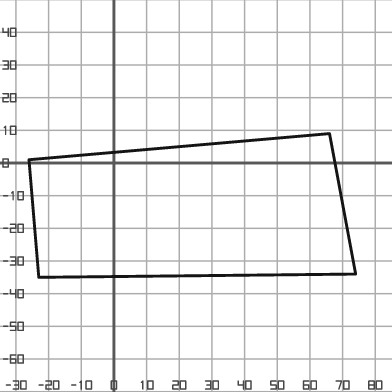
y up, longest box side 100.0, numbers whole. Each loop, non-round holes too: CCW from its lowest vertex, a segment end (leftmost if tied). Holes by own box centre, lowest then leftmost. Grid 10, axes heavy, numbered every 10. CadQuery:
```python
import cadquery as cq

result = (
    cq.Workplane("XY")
    .moveTo(-23.0, -35.0)
    .lineTo(74.0, -34.0)
    .lineTo(66.0, 9.0)
    .lineTo(-26.0, 1.0)
    .close()
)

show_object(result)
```